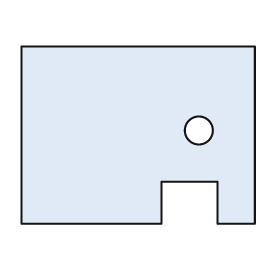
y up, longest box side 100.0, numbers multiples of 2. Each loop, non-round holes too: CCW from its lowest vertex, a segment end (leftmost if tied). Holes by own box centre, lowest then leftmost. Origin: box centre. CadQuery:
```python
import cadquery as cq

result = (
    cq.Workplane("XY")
    .moveTo(-50.0, -38.0)
    .lineTo(10.0, -38.0)
    .lineTo(10.0, -20.0)
    .lineTo(34.0, -20.0)
    .lineTo(34.0, -38.0)
    .lineTo(50.0, -38.0)
    .lineTo(50.0, 38.0)
    .lineTo(-50.0, 38.0)
    .close()
    .moveTo(26.0, 2.0)
    .circle(6.0)
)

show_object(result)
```